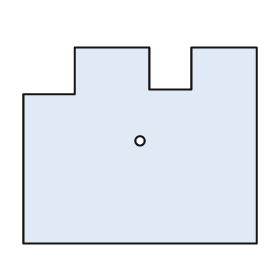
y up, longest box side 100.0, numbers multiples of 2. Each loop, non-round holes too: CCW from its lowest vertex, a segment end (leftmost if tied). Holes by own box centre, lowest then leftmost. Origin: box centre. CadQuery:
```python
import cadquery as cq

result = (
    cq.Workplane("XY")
    .moveTo(-50.0, -42.0)
    .lineTo(50.0, -42.0)
    .lineTo(50.0, 42.0)
    .lineTo(22.0, 42.0)
    .lineTo(22.0, 24.0)
    .lineTo(4.0, 24.0)
    .lineTo(4.0, 42.0)
    .lineTo(-28.0, 42.0)
    .lineTo(-28.0, 22.0)
    .lineTo(-50.0, 22.0)
    .close()
    .moveTo(0.0, 2.0)
    .circle(2.0)
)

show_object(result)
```